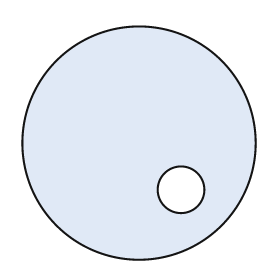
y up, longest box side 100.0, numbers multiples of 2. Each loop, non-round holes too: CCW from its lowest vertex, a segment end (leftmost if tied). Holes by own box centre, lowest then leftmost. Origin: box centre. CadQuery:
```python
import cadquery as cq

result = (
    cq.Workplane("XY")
    .moveTo(0.0, 0.0)
    .circle(50.0)
    .moveTo(18.0, -20.0)
    .circle(10.0)
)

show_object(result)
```